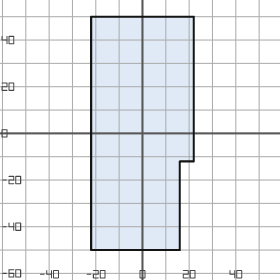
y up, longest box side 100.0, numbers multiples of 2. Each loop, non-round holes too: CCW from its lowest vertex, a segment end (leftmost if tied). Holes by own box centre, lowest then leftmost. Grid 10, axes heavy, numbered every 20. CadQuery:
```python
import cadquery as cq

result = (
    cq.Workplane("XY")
    .moveTo(-22.0, -50.0)
    .lineTo(16.0, -50.0)
    .lineTo(16.0, -12.0)
    .lineTo(22.0, -12.0)
    .lineTo(22.0, 50.0)
    .lineTo(-22.0, 50.0)
    .close()
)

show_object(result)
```